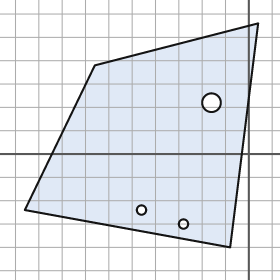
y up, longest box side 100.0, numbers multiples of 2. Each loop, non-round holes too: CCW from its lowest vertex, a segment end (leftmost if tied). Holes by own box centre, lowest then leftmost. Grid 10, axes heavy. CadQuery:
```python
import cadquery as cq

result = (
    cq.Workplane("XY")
    .moveTo(-8.0, -40.0)
    .lineTo(4.0, 56.0)
    .lineTo(-66.0, 38.0)
    .lineTo(-96.0, -24.0)
    .close()
    .moveTo(-28.0, -30.0)
    .circle(2.0)
    .moveTo(-46.0, -24.0)
    .circle(2.0)
    .moveTo(-16.0, 22.0)
    .circle(4.0)
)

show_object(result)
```